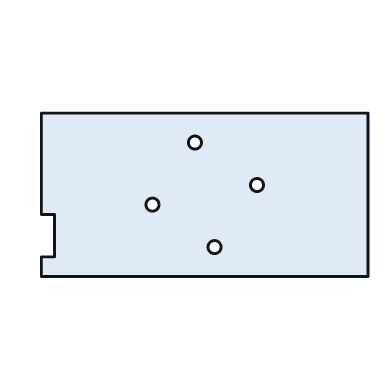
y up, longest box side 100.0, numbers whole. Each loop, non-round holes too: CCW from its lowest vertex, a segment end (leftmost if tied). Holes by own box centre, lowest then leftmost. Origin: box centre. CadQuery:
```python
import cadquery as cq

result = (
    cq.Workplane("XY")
    .moveTo(-50.0, -25.0)
    .lineTo(50.0, -25.0)
    .lineTo(50.0, 25.0)
    .lineTo(-50.0, 25.0)
    .lineTo(-50.0, -6.0)
    .lineTo(-46.0, -6.0)
    .lineTo(-46.0, -19.0)
    .lineTo(-50.0, -19.0)
    .close()
    .moveTo(3.0, -16.0)
    .circle(2.0)
    .moveTo(-16.0, -3.0)
    .circle(2.0)
    .moveTo(16.0, 3.0)
    .circle(2.0)
    .moveTo(-3.0, 16.0)
    .circle(2.0)
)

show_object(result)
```